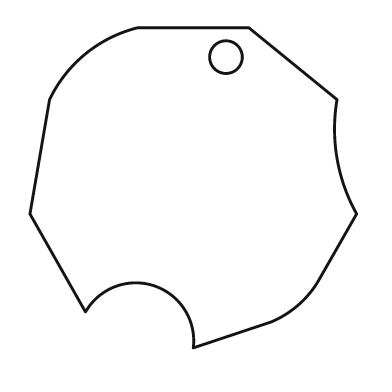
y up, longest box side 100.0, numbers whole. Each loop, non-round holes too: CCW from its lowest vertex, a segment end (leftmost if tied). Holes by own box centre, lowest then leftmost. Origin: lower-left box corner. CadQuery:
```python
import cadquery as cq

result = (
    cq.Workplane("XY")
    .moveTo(50.0, 0.0)
    .lineTo(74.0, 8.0)
    .threePointArc((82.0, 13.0), (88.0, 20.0))
    .lineTo(100.0, 41.0)
    .threePointArc((94.0, 58.0), (94.0, 76.0))
    .lineTo(67.0, 98.0)
    .lineTo(33.0, 98.0)
    .threePointArc((17.0, 90.0), (6.0, 76.0))
    .lineTo(0.0, 41.0)
    .lineTo(17.0, 11.0)
    .threePointArc((38.0, 19.0), (50.0, 0.0))
    .close()
    .moveTo(60.0, 89.0)
    .circle(5.0)
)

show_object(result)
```